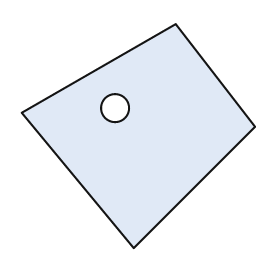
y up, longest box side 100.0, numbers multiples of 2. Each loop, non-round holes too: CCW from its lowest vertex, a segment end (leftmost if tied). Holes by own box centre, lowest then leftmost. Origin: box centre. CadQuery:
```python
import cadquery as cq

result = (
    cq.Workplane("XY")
    .moveTo(-2.0, -48.0)
    .lineTo(50.0, 4.0)
    .lineTo(16.0, 48.0)
    .lineTo(-50.0, 10.0)
    .close()
    .moveTo(-10.0, 12.0)
    .circle(6.0)
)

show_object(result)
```